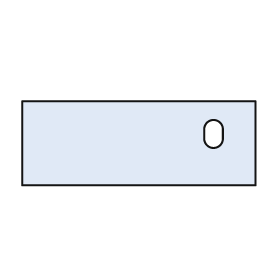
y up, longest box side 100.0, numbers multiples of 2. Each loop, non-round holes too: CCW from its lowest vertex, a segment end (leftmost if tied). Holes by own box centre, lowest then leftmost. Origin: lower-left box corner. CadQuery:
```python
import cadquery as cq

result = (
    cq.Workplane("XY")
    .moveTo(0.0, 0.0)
    .lineTo(100.0, 0.0)
    .lineTo(100.0, 36.0)
    .lineTo(0.0, 36.0)
    .close()
    .moveTo(78.0, 20.0)
    .threePointArc((82.0, 16.0), (86.0, 20.0))
    .lineTo(86.0, 24.0)
    .threePointArc((82.0, 28.0), (78.0, 24.0))
    .close()
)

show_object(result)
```